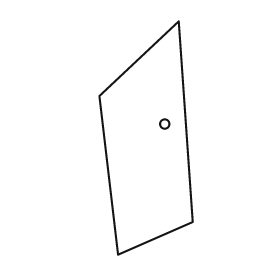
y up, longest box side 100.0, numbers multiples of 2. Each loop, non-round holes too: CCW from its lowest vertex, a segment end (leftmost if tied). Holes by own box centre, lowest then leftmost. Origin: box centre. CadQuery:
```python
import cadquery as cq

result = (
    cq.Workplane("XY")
    .moveTo(-12.0, -50.0)
    .lineTo(20.0, -36.0)
    .lineTo(14.0, 50.0)
    .lineTo(-20.0, 18.0)
    .close()
    .moveTo(8.0, 6.0)
    .circle(2.0)
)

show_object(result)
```